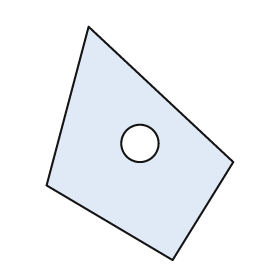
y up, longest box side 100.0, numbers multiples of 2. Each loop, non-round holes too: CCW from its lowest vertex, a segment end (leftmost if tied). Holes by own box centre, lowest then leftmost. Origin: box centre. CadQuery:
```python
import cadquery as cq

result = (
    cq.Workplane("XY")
    .moveTo(14.0, -50.0)
    .lineTo(40.0, -8.0)
    .lineTo(-22.0, 50.0)
    .lineTo(-40.0, -18.0)
    .close()
    .moveTo(0.0, 0.0)
    .circle(8.0)
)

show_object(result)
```